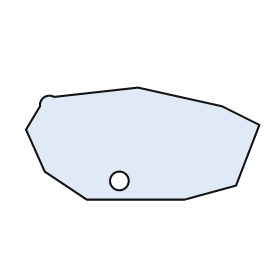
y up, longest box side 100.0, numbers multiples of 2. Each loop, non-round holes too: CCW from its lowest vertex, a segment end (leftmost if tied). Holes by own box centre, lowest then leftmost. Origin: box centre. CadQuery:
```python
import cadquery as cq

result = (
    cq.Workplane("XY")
    .moveTo(-24.0, -24.0)
    .lineTo(18.0, -24.0)
    .lineTo(40.0, -18.0)
    .lineTo(50.0, 8.0)
    .lineTo(34.0, 16.0)
    .lineTo(-2.0, 24.0)
    .lineTo(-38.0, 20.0)
    .threePointArc((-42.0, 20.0), (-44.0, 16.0))
    .lineTo(-50.0, 6.0)
    .lineTo(-42.0, -12.0)
    .close()
    .moveTo(-10.0, -16.0)
    .circle(4.0)
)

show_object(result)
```